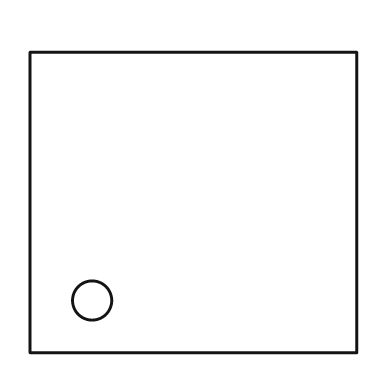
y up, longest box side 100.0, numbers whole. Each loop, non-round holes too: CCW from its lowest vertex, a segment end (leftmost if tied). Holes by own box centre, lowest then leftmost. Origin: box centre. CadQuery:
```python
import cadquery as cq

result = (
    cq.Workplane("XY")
    .moveTo(-50.0, -46.0)
    .lineTo(50.0, -46.0)
    .lineTo(50.0, 46.0)
    .lineTo(-50.0, 46.0)
    .close()
    .moveTo(-31.0, -30.0)
    .circle(6.0)
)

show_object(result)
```